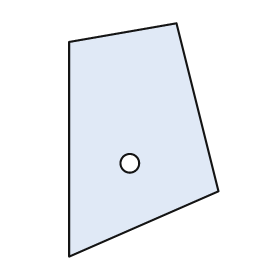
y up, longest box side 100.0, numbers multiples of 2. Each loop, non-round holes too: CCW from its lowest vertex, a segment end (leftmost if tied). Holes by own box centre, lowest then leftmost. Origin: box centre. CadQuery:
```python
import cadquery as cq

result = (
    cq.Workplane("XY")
    .moveTo(-32.0, -50.0)
    .lineTo(32.0, -22.0)
    .lineTo(14.0, 50.0)
    .lineTo(-32.0, 42.0)
    .close()
    .moveTo(-6.0, -10.0)
    .circle(4.0)
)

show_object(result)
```